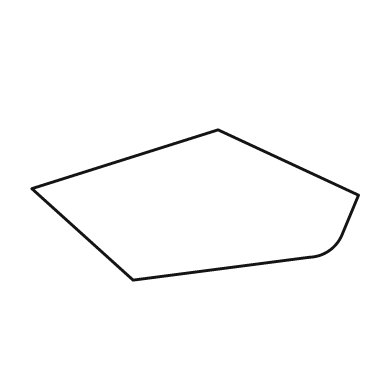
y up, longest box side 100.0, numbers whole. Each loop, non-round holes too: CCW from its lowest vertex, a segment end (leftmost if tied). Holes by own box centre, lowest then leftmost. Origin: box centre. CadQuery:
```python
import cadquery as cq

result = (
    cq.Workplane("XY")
    .moveTo(-19.0, -23.0)
    .lineTo(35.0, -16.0)
    .threePointArc((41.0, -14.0), (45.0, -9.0))
    .lineTo(50.0, 3.0)
    .lineTo(7.0, 23.0)
    .lineTo(-50.0, 5.0)
    .close()
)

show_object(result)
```